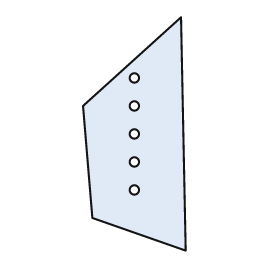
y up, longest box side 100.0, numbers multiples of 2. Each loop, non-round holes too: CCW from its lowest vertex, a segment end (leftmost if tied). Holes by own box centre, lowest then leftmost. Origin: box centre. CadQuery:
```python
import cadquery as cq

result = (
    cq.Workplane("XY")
    .moveTo(22.0, -50.0)
    .lineTo(20.0, 50.0)
    .lineTo(-22.0, 12.0)
    .lineTo(-18.0, -36.0)
    .close()
    .moveTo(0.0, -24.0)
    .circle(2.0)
    .moveTo(0.0, -12.0)
    .circle(2.0)
    .moveTo(0.0, 0.0)
    .circle(2.0)
    .moveTo(0.0, 12.0)
    .circle(2.0)
    .moveTo(0.0, 24.0)
    .circle(2.0)
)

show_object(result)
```